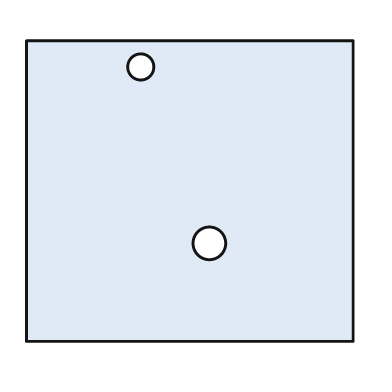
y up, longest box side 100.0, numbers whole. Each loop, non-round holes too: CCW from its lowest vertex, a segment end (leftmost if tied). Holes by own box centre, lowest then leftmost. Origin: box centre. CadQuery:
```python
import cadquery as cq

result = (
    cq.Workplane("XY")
    .moveTo(-50.0, -46.0)
    .lineTo(50.0, -46.0)
    .lineTo(50.0, 46.0)
    .lineTo(-50.0, 46.0)
    .close()
    .moveTo(6.0, -16.0)
    .circle(5.0)
    .moveTo(-15.0, 38.0)
    .circle(4.0)
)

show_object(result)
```